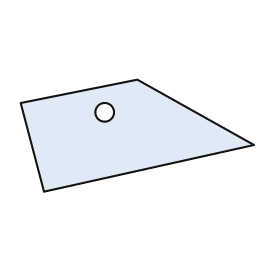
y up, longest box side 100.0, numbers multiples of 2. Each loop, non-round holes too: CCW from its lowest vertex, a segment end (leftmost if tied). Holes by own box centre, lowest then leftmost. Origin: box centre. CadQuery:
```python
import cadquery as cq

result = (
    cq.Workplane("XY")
    .moveTo(-40.0, -24.0)
    .lineTo(50.0, -4.0)
    .lineTo(0.0, 24.0)
    .lineTo(-50.0, 14.0)
    .close()
    .moveTo(-14.0, 10.0)
    .circle(4.0)
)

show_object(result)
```